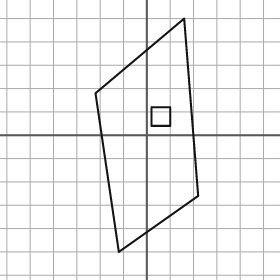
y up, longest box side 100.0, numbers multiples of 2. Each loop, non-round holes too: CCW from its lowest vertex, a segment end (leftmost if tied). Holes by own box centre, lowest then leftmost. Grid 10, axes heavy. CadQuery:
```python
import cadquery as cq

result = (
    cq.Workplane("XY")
    .moveTo(-12.0, -50.0)
    .lineTo(22.0, -26.0)
    .lineTo(16.0, 50.0)
    .lineTo(-22.0, 18.0)
    .close()
    .moveTo(2.0, 4.0)
    .lineTo(10.0, 4.0)
    .lineTo(10.0, 12.0)
    .lineTo(2.0, 12.0)
    .close()
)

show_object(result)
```